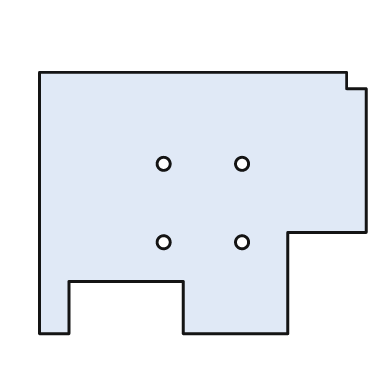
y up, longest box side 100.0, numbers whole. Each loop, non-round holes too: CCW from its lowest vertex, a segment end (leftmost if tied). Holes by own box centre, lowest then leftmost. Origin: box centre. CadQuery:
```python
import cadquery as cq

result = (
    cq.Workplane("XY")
    .moveTo(-50.0, -40.0)
    .lineTo(-41.0, -40.0)
    .lineTo(-41.0, -24.0)
    .lineTo(-6.0, -24.0)
    .lineTo(-6.0, -40.0)
    .lineTo(26.0, -40.0)
    .lineTo(26.0, -9.0)
    .lineTo(50.0, -9.0)
    .lineTo(50.0, 35.0)
    .lineTo(44.0, 35.0)
    .lineTo(44.0, 40.0)
    .lineTo(-50.0, 40.0)
    .close()
    .moveTo(-12.0, -12.0)
    .circle(2.0)
    .moveTo(12.0, -12.0)
    .circle(2.0)
    .moveTo(-12.0, 12.0)
    .circle(2.0)
    .moveTo(12.0, 12.0)
    .circle(2.0)
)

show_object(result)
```